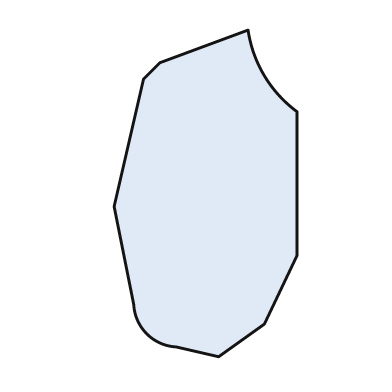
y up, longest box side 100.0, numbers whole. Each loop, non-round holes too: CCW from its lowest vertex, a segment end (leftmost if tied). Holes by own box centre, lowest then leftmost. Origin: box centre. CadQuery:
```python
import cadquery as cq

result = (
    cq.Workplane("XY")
    .moveTo(4.0, -50.0)
    .lineTo(18.0, -40.0)
    .lineTo(28.0, -19.0)
    .lineTo(28.0, 25.0)
    .threePointArc((18.0, 36.0), (13.0, 50.0))
    .lineTo(-14.0, 40.0)
    .lineTo(-19.0, 35.0)
    .lineTo(-28.0, -4.0)
    .lineTo(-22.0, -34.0)
    .threePointArc((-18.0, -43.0), (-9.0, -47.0))
    .close()
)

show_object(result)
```